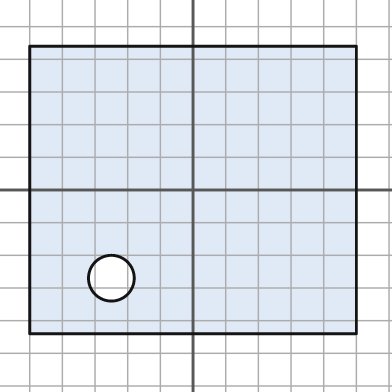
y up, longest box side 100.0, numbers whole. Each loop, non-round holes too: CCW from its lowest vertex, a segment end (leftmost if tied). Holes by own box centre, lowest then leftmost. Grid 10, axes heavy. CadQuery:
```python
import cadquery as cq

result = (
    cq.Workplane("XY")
    .moveTo(-50.0, -44.0)
    .lineTo(50.0, -44.0)
    .lineTo(50.0, 44.0)
    .lineTo(-50.0, 44.0)
    .close()
    .moveTo(-25.0, -27.0)
    .circle(7.0)
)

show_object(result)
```